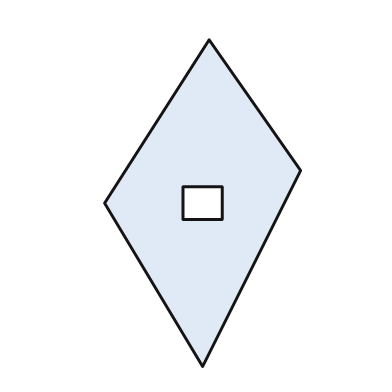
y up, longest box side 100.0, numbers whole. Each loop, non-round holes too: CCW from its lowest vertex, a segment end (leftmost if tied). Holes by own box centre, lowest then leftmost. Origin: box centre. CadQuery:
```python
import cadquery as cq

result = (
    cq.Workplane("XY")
    .moveTo(0.0, -50.0)
    .lineTo(30.0, 10.0)
    .lineTo(2.0, 50.0)
    .lineTo(-30.0, 0.0)
    .close()
    .moveTo(-6.0, -5.0)
    .lineTo(6.0, -5.0)
    .lineTo(6.0, 5.0)
    .lineTo(-6.0, 5.0)
    .close()
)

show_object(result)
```